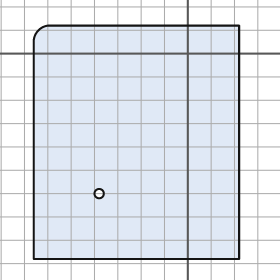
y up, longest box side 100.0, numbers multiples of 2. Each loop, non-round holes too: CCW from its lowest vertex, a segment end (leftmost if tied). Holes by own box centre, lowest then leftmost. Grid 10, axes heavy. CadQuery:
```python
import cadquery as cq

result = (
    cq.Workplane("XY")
    .moveTo(-66.0, -88.0)
    .lineTo(22.0, -88.0)
    .lineTo(22.0, 12.0)
    .lineTo(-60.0, 12.0)
    .threePointArc((-64.0, 10.0), (-66.0, 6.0))
    .close()
    .moveTo(-38.0, -60.0)
    .circle(2.0)
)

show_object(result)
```